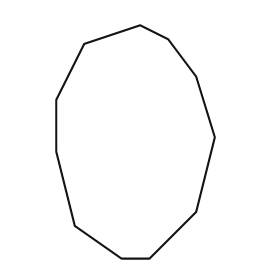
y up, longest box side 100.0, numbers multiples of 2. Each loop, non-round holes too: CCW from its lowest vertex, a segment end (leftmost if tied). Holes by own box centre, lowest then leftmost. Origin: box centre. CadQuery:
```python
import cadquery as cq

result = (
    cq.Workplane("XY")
    .moveTo(-6.0, -50.0)
    .lineTo(6.0, -50.0)
    .lineTo(26.0, -30.0)
    .lineTo(34.0, 2.0)
    .lineTo(26.0, 28.0)
    .lineTo(14.0, 44.0)
    .lineTo(2.0, 50.0)
    .lineTo(-22.0, 42.0)
    .lineTo(-34.0, 18.0)
    .lineTo(-34.0, -4.0)
    .lineTo(-26.0, -36.0)
    .close()
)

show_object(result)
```